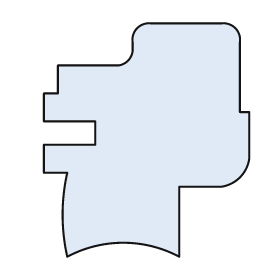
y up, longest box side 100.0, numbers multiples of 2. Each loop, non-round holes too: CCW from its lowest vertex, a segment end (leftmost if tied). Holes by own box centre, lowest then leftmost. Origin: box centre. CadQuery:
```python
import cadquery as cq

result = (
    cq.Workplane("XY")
    .moveTo(-34.0, -50.0)
    .threePointArc((-10.0, -44.0), (14.0, -50.0))
    .lineTo(14.0, -20.0)
    .lineTo(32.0, -20.0)
    .threePointArc((40.0, -16.0), (44.0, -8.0))
    .lineTo(44.0, 12.0)
    .lineTo(40.0, 12.0)
    .lineTo(40.0, 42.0)
    .threePointArc((38.0, 48.0), (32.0, 50.0))
    .lineTo(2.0, 50.0)
    .threePointArc((-4.0, 48.0), (-6.0, 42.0))
    .lineTo(-6.0, 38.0)
    .threePointArc((-8.0, 34.0), (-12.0, 32.0))
    .lineTo(-38.0, 32.0)
    .lineTo(-38.0, 20.0)
    .lineTo(-44.0, 20.0)
    .lineTo(-44.0, 8.0)
    .lineTo(-22.0, 8.0)
    .lineTo(-22.0, -2.0)
    .lineTo(-44.0, -2.0)
    .lineTo(-44.0, -14.0)
    .lineTo(-34.0, -14.0)
    .threePointArc((-36.0, -32.0), (-34.0, -50.0))
    .close()
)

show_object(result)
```